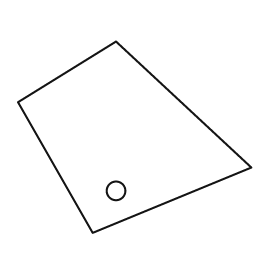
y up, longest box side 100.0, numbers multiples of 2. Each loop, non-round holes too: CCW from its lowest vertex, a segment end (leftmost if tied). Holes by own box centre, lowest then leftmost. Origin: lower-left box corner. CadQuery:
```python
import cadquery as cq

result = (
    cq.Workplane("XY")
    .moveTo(32.0, 0.0)
    .lineTo(100.0, 28.0)
    .lineTo(42.0, 82.0)
    .lineTo(0.0, 56.0)
    .close()
    .moveTo(42.0, 18.0)
    .circle(4.0)
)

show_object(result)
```